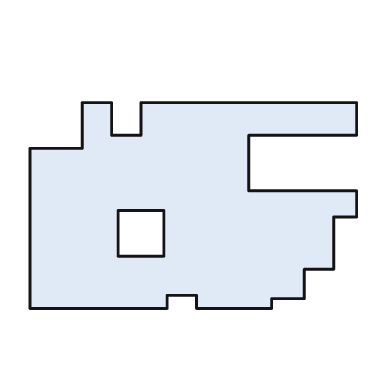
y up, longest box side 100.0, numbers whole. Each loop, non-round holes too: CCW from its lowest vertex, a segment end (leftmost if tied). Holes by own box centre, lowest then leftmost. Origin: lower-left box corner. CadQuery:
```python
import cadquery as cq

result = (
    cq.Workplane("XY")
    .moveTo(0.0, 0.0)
    .lineTo(42.0, 0.0)
    .lineTo(42.0, 4.0)
    .lineTo(51.0, 4.0)
    .lineTo(51.0, 0.0)
    .lineTo(74.0, 0.0)
    .lineTo(74.0, 3.0)
    .lineTo(84.0, 3.0)
    .lineTo(84.0, 12.0)
    .lineTo(93.0, 12.0)
    .lineTo(93.0, 28.0)
    .lineTo(100.0, 28.0)
    .lineTo(100.0, 36.0)
    .lineTo(67.0, 36.0)
    .lineTo(67.0, 53.0)
    .lineTo(100.0, 53.0)
    .lineTo(100.0, 63.0)
    .lineTo(34.0, 63.0)
    .lineTo(34.0, 53.0)
    .lineTo(25.0, 53.0)
    .lineTo(25.0, 63.0)
    .lineTo(16.0, 63.0)
    .lineTo(16.0, 49.0)
    .lineTo(0.0, 49.0)
    .close()
    .moveTo(27.0, 16.0)
    .lineTo(41.0, 16.0)
    .lineTo(41.0, 30.0)
    .lineTo(27.0, 30.0)
    .close()
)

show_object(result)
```